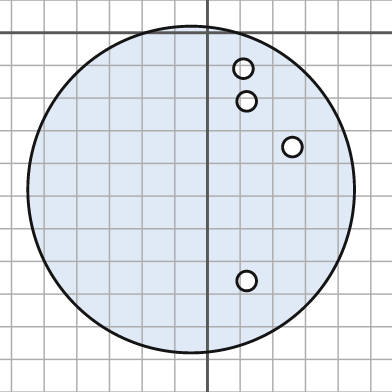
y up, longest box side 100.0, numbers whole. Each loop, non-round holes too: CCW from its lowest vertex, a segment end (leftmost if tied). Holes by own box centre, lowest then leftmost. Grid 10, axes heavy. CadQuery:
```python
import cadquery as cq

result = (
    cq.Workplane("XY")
    .moveTo(-5.0, -48.0)
    .circle(50.0)
    .moveTo(12.0, -76.0)
    .circle(3.0)
    .moveTo(26.0, -35.0)
    .circle(3.0)
    .moveTo(12.0, -21.0)
    .circle(3.0)
    .moveTo(11.0, -11.0)
    .circle(3.0)
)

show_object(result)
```